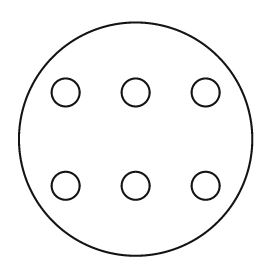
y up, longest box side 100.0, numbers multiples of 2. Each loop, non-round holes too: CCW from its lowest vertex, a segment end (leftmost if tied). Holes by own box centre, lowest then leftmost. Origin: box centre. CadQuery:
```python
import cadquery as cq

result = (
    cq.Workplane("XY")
    .moveTo(0.0, 0.0)
    .circle(50.0)
    .moveTo(-30.0, -20.0)
    .circle(6.0)
    .moveTo(0.0, -20.0)
    .circle(6.0)
    .moveTo(30.0, -20.0)
    .circle(6.0)
    .moveTo(-30.0, 20.0)
    .circle(6.0)
    .moveTo(0.0, 20.0)
    .circle(6.0)
    .moveTo(30.0, 20.0)
    .circle(6.0)
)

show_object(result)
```